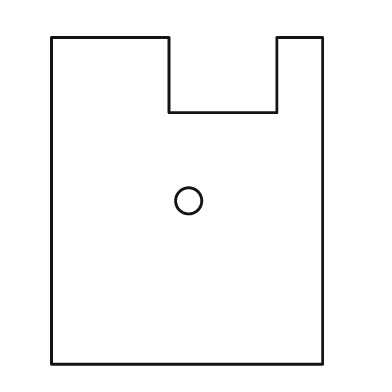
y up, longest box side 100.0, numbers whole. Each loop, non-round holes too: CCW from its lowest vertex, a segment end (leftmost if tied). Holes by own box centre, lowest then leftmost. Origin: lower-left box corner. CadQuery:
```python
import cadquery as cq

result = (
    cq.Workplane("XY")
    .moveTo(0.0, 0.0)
    .lineTo(83.0, 0.0)
    .lineTo(83.0, 100.0)
    .lineTo(69.0, 100.0)
    .lineTo(69.0, 77.0)
    .lineTo(36.0, 77.0)
    .lineTo(36.0, 100.0)
    .lineTo(0.0, 100.0)
    .close()
    .moveTo(42.0, 50.0)
    .circle(4.0)
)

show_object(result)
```